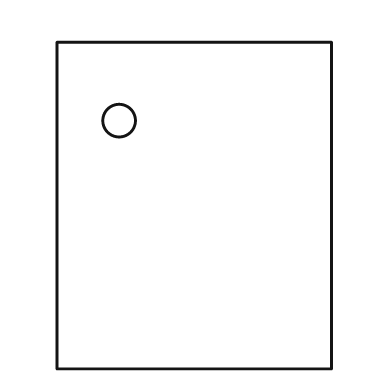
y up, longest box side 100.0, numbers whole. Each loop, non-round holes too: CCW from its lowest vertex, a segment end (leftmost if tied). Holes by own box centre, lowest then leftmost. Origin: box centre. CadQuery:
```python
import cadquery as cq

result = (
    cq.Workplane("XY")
    .moveTo(-42.0, -50.0)
    .lineTo(42.0, -50.0)
    .lineTo(42.0, 50.0)
    .lineTo(-42.0, 50.0)
    .close()
    .moveTo(-23.0, 26.0)
    .circle(5.0)
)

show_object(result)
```